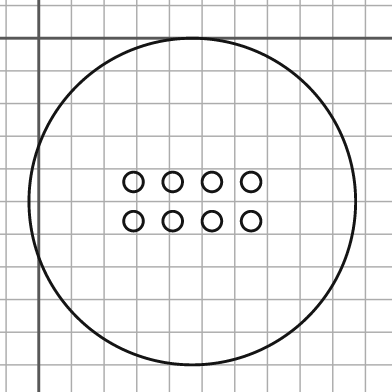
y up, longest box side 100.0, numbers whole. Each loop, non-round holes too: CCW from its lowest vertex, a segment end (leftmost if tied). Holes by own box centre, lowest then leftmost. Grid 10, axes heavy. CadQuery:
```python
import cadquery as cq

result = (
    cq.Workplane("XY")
    .moveTo(47.0, -50.0)
    .circle(50.0)
    .moveTo(29.0, -56.0)
    .circle(3.0)
    .moveTo(41.0, -56.0)
    .circle(3.0)
    .moveTo(53.0, -56.0)
    .circle(3.0)
    .moveTo(65.0, -56.0)
    .circle(3.0)
    .moveTo(29.0, -44.0)
    .circle(3.0)
    .moveTo(41.0, -44.0)
    .circle(3.0)
    .moveTo(53.0, -44.0)
    .circle(3.0)
    .moveTo(65.0, -44.0)
    .circle(3.0)
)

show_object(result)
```